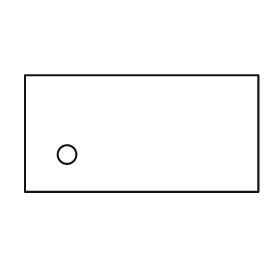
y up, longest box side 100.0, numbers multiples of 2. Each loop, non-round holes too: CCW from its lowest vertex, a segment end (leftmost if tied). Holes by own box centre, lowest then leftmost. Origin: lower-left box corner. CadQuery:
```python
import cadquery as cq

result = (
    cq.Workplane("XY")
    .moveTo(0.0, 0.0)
    .lineTo(100.0, 0.0)
    .lineTo(100.0, 50.0)
    .lineTo(0.0, 50.0)
    .close()
    .moveTo(18.0, 16.0)
    .circle(4.0)
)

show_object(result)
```